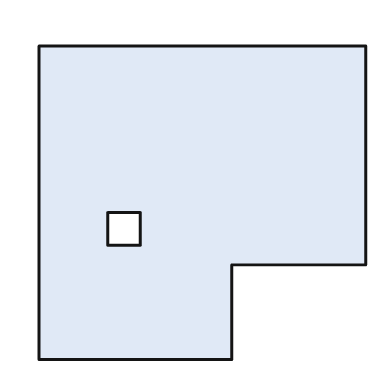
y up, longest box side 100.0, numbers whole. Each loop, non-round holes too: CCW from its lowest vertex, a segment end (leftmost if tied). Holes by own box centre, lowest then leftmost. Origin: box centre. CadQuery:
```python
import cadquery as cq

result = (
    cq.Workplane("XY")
    .moveTo(-50.0, -48.0)
    .lineTo(9.0, -48.0)
    .lineTo(9.0, -19.0)
    .lineTo(50.0, -19.0)
    .lineTo(50.0, 48.0)
    .lineTo(-50.0, 48.0)
    .close()
    .moveTo(-29.0, -13.0)
    .lineTo(-19.0, -13.0)
    .lineTo(-19.0, -3.0)
    .lineTo(-29.0, -3.0)
    .close()
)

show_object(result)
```